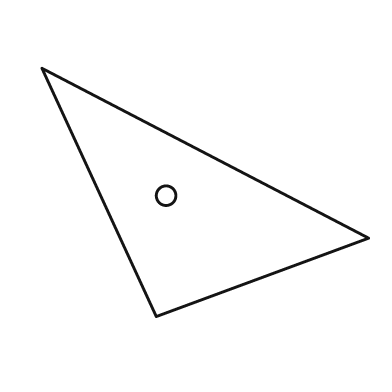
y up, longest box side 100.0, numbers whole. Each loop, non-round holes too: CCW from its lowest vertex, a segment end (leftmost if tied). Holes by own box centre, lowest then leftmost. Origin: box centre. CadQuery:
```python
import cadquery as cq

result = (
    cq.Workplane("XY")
    .moveTo(-15.0, -38.0)
    .lineTo(50.0, -14.0)
    .lineTo(-50.0, 38.0)
    .close()
    .moveTo(-12.0, -1.0)
    .circle(3.0)
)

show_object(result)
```